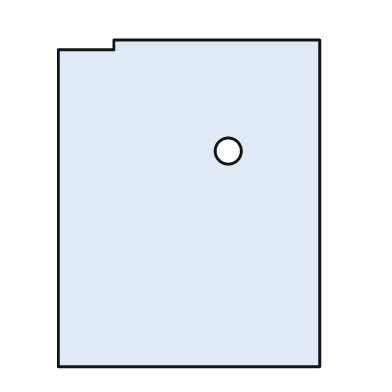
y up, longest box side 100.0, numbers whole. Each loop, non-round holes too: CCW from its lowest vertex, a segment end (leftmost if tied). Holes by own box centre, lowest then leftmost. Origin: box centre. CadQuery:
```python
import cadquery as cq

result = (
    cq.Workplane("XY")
    .moveTo(-40.0, -50.0)
    .lineTo(40.0, -50.0)
    .lineTo(40.0, 50.0)
    .lineTo(-23.0, 50.0)
    .lineTo(-23.0, 47.0)
    .lineTo(-40.0, 47.0)
    .close()
    .moveTo(12.0, 16.0)
    .circle(4.0)
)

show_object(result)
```